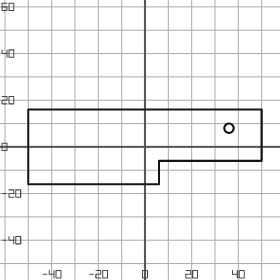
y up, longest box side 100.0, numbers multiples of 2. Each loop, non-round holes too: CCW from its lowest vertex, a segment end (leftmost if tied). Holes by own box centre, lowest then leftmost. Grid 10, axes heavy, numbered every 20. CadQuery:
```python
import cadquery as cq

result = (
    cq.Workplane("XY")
    .moveTo(-50.0, -16.0)
    .lineTo(6.0, -16.0)
    .lineTo(6.0, -6.0)
    .lineTo(50.0, -6.0)
    .lineTo(50.0, 16.0)
    .lineTo(-50.0, 16.0)
    .close()
    .moveTo(36.0, 8.0)
    .circle(2.0)
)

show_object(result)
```